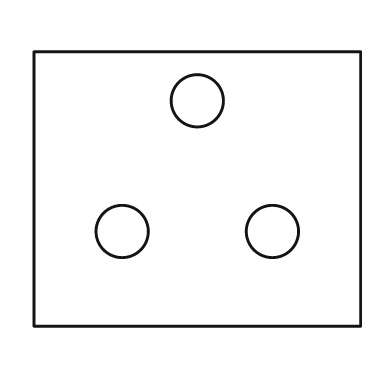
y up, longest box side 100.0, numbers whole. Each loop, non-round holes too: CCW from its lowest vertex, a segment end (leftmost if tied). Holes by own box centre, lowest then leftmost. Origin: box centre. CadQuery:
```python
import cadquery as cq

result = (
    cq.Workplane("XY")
    .moveTo(-50.0, -42.0)
    .lineTo(50.0, -42.0)
    .lineTo(50.0, 42.0)
    .lineTo(-50.0, 42.0)
    .close()
    .moveTo(-23.0, -13.0)
    .circle(8.0)
    .moveTo(23.0, -13.0)
    .circle(8.0)
    .moveTo(0.0, 27.0)
    .circle(8.0)
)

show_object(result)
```